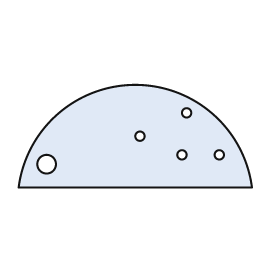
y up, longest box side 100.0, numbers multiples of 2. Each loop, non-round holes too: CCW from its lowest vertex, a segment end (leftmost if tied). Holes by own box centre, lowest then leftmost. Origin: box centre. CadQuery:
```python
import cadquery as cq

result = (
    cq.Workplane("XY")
    .moveTo(-50.0, -22.0)
    .lineTo(50.0, -22.0)
    .threePointArc((0.0, 22.0), (-50.0, -22.0))
    .close()
    .moveTo(-38.0, -12.0)
    .circle(4.0)
    .moveTo(20.0, -8.0)
    .circle(2.0)
    .moveTo(36.0, -8.0)
    .circle(2.0)
    .moveTo(2.0, 0.0)
    .circle(2.0)
    .moveTo(22.0, 10.0)
    .circle(2.0)
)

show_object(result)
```